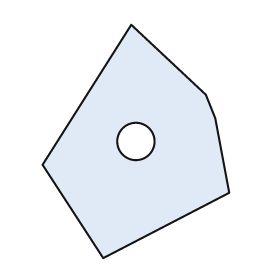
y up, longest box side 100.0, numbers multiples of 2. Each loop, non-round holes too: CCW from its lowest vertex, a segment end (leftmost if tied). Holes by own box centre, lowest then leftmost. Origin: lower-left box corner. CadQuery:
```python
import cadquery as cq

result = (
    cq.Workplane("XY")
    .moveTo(26.0, 0.0)
    .lineTo(80.0, 28.0)
    .lineTo(74.0, 60.0)
    .lineTo(70.0, 70.0)
    .lineTo(38.0, 100.0)
    .lineTo(0.0, 40.0)
    .close()
    .moveTo(40.0, 50.0)
    .circle(8.0)
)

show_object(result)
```